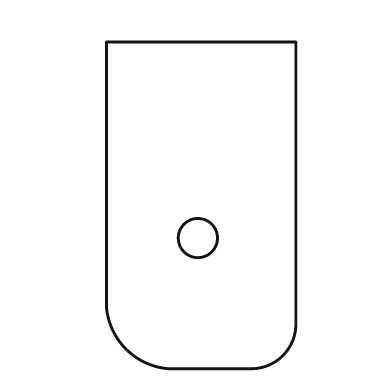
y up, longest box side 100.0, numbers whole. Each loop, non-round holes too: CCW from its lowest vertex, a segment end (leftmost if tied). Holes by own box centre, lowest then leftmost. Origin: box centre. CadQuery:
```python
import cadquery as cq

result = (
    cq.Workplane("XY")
    .moveTo(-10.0, -50.0)
    .lineTo(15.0, -50.0)
    .threePointArc((25.0, -46.0), (29.0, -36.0))
    .lineTo(29.0, 50.0)
    .lineTo(-29.0, 50.0)
    .lineTo(-29.0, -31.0)
    .threePointArc((-23.0, -44.0), (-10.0, -50.0))
    .close()
    .moveTo(-1.0, -10.0)
    .circle(6.0)
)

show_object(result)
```